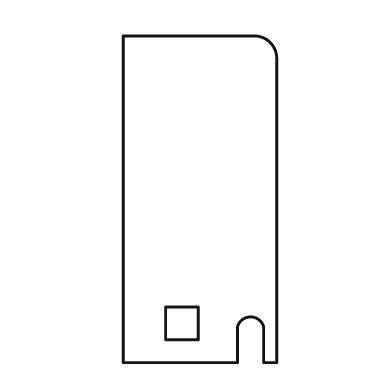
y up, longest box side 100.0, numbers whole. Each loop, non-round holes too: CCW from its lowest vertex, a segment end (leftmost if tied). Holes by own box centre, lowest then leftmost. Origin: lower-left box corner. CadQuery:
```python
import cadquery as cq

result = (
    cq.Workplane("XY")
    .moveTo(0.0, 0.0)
    .lineTo(35.0, 0.0)
    .lineTo(35.0, 11.0)
    .threePointArc((39.0, 14.0), (43.0, 11.0))
    .lineTo(43.0, 0.0)
    .lineTo(47.0, 0.0)
    .lineTo(47.0, 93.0)
    .threePointArc((45.0, 98.0), (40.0, 100.0))
    .lineTo(0.0, 100.0)
    .close()
    .moveTo(13.0, 7.0)
    .lineTo(23.0, 7.0)
    .lineTo(23.0, 17.0)
    .lineTo(13.0, 17.0)
    .close()
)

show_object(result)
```